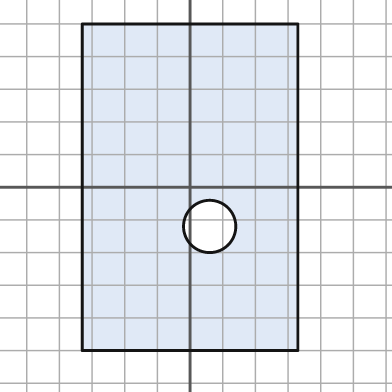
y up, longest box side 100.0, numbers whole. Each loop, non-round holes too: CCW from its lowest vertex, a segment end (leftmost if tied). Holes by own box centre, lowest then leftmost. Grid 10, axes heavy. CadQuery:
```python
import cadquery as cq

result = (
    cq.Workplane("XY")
    .moveTo(-33.0, -50.0)
    .lineTo(33.0, -50.0)
    .lineTo(33.0, 50.0)
    .lineTo(-33.0, 50.0)
    .close()
    .moveTo(6.0, -12.0)
    .circle(8.0)
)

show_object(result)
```